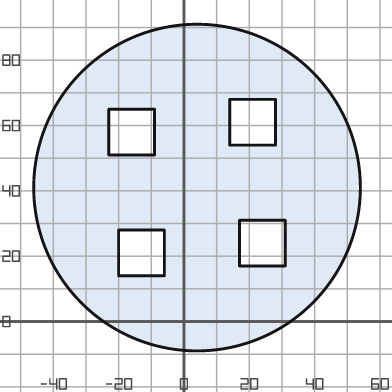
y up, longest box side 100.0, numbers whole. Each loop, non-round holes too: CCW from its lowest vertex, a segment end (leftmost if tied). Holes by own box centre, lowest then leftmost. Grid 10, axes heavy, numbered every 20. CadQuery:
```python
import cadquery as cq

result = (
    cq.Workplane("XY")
    .moveTo(4.0, 41.0)
    .circle(50.0)
    .moveTo(-20.0, 14.0)
    .lineTo(-6.0, 14.0)
    .lineTo(-6.0, 28.0)
    .lineTo(-20.0, 28.0)
    .close()
    .moveTo(17.0, 17.0)
    .lineTo(31.0, 17.0)
    .lineTo(31.0, 31.0)
    .lineTo(17.0, 31.0)
    .close()
    .moveTo(-23.0, 51.0)
    .lineTo(-9.0, 51.0)
    .lineTo(-9.0, 65.0)
    .lineTo(-23.0, 65.0)
    .close()
    .moveTo(14.0, 54.0)
    .lineTo(28.0, 54.0)
    .lineTo(28.0, 68.0)
    .lineTo(14.0, 68.0)
    .close()
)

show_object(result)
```